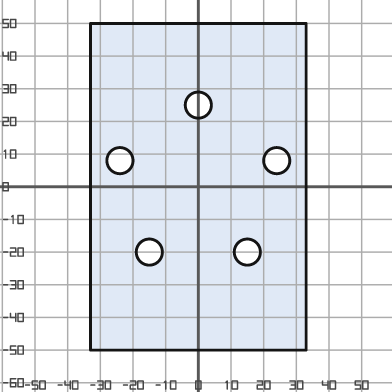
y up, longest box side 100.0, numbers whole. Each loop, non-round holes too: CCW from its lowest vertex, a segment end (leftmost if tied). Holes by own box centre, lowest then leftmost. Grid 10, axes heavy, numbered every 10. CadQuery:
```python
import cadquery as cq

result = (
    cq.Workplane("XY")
    .moveTo(-33.0, -50.0)
    .lineTo(33.0, -50.0)
    .lineTo(33.0, 50.0)
    .lineTo(-33.0, 50.0)
    .close()
    .moveTo(-15.0, -20.0)
    .circle(4.0)
    .moveTo(15.0, -20.0)
    .circle(4.0)
    .moveTo(-24.0, 8.0)
    .circle(4.0)
    .moveTo(24.0, 8.0)
    .circle(4.0)
    .moveTo(0.0, 25.0)
    .circle(4.0)
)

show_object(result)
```